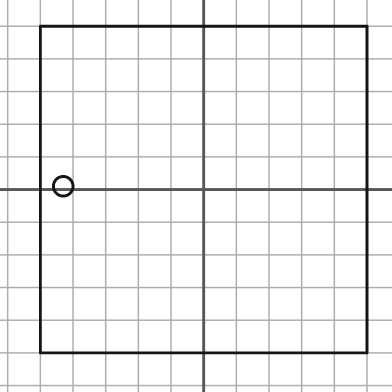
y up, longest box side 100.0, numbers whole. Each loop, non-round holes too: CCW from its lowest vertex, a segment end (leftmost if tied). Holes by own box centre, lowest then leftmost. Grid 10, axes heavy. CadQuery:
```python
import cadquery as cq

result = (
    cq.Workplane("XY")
    .moveTo(-50.0, -50.0)
    .lineTo(50.0, -50.0)
    .lineTo(50.0, 50.0)
    .lineTo(-50.0, 50.0)
    .close()
    .moveTo(-43.0, 1.0)
    .circle(3.0)
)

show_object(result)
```